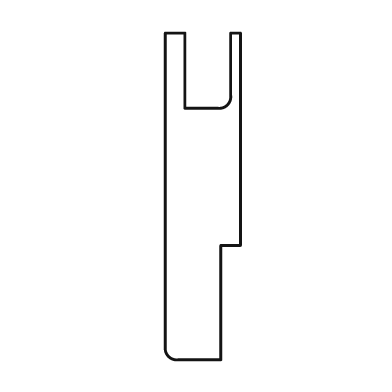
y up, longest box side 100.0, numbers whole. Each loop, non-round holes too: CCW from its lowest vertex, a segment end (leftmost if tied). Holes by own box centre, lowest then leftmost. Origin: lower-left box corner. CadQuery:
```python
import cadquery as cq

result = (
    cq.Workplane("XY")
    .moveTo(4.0, 0.0)
    .lineTo(17.0, 0.0)
    .lineTo(17.0, 35.0)
    .lineTo(23.0, 35.0)
    .lineTo(23.0, 100.0)
    .lineTo(20.0, 100.0)
    .lineTo(20.0, 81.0)
    .threePointArc((19.0, 78.0), (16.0, 77.0))
    .lineTo(6.0, 77.0)
    .lineTo(6.0, 100.0)
    .lineTo(0.0, 100.0)
    .lineTo(0.0, 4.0)
    .threePointArc((1.0, 1.0), (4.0, 0.0))
    .close()
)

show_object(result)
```